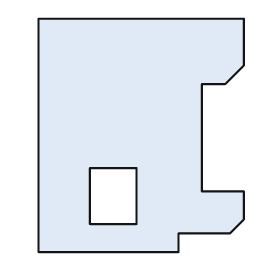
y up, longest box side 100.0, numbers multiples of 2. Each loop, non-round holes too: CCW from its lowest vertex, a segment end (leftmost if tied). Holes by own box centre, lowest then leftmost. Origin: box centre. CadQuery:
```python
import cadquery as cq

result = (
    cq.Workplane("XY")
    .moveTo(-44.0, -50.0)
    .lineTo(16.0, -50.0)
    .lineTo(16.0, -42.0)
    .lineTo(38.0, -42.0)
    .lineTo(44.0, -36.0)
    .lineTo(44.0, -24.0)
    .lineTo(26.0, -24.0)
    .lineTo(26.0, 22.0)
    .lineTo(36.0, 22.0)
    .lineTo(44.0, 30.0)
    .lineTo(44.0, 50.0)
    .lineTo(-44.0, 50.0)
    .close()
    .moveTo(-22.0, -38.0)
    .lineTo(-2.0, -38.0)
    .lineTo(-2.0, -14.0)
    .lineTo(-22.0, -14.0)
    .close()
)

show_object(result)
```